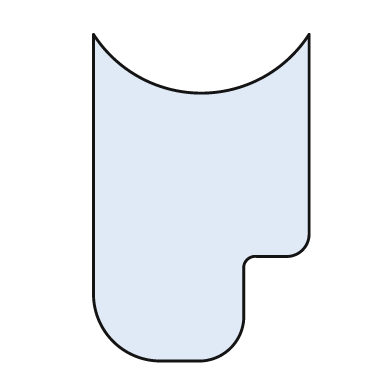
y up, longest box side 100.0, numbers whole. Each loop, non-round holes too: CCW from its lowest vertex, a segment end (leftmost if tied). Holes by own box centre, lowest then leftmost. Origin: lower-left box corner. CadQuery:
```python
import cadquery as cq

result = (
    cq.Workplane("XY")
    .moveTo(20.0, 0.0)
    .lineTo(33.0, 0.0)
    .threePointArc((42.0, 4.0), (46.0, 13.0))
    .lineTo(46.0, 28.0)
    .threePointArc((47.0, 31.0), (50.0, 32.0))
    .lineTo(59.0, 32.0)
    .threePointArc((64.0, 34.0), (66.0, 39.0))
    .lineTo(66.0, 100.0)
    .threePointArc((33.0, 82.0), (0.0, 100.0))
    .lineTo(0.0, 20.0)
    .threePointArc((6.0, 6.0), (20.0, 0.0))
    .close()
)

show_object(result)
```